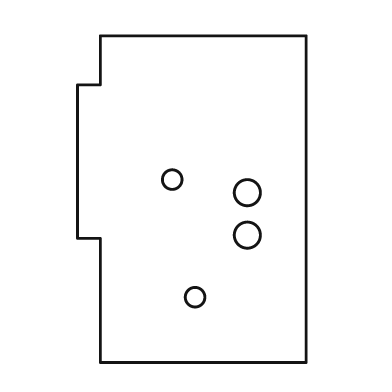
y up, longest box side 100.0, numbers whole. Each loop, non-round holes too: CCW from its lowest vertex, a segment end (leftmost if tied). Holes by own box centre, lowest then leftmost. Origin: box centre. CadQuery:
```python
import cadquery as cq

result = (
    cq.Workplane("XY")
    .moveTo(-28.0, -50.0)
    .lineTo(35.0, -50.0)
    .lineTo(35.0, 50.0)
    .lineTo(-28.0, 50.0)
    .lineTo(-28.0, 35.0)
    .lineTo(-35.0, 35.0)
    .lineTo(-35.0, -12.0)
    .lineTo(-28.0, -12.0)
    .close()
    .moveTo(1.0, -30.0)
    .circle(3.0)
    .moveTo(17.0, -11.0)
    .circle(4.0)
    .moveTo(17.0, 2.0)
    .circle(4.0)
    .moveTo(-6.0, 6.0)
    .circle(3.0)
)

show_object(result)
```